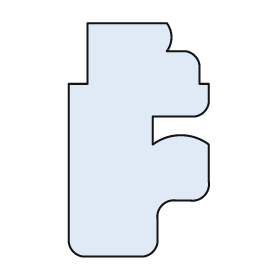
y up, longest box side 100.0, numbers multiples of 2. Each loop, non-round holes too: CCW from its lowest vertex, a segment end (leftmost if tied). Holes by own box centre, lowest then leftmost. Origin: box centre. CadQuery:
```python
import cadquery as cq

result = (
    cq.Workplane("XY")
    .moveTo(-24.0, -50.0)
    .lineTo(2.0, -50.0)
    .threePointArc((6.0, -48.0), (8.0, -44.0))
    .lineTo(8.0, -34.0)
    .threePointArc((10.0, -28.0), (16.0, -26.0))
    .lineTo(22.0, -26.0)
    .threePointArc((28.0, -24.0), (30.0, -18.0))
    .lineTo(30.0, -2.0)
    .threePointArc((18.0, 2.0), (6.0, -2.0))
    .lineTo(6.0, 10.0)
    .lineTo(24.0, 10.0)
    .threePointArc((28.0, 12.0), (30.0, 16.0))
    .lineTo(30.0, 24.0)
    .lineTo(26.0, 24.0)
    .lineTo(26.0, 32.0)
    .threePointArc((24.0, 36.0), (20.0, 38.0))
    .lineTo(12.0, 38.0)
    .threePointArc((14.0, 44.0), (12.0, 50.0))
    .lineTo(-22.0, 50.0)
    .lineTo(-22.0, 24.0)
    .lineTo(-30.0, 24.0)
    .lineTo(-30.0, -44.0)
    .threePointArc((-28.0, -48.0), (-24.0, -50.0))
    .close()
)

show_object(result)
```